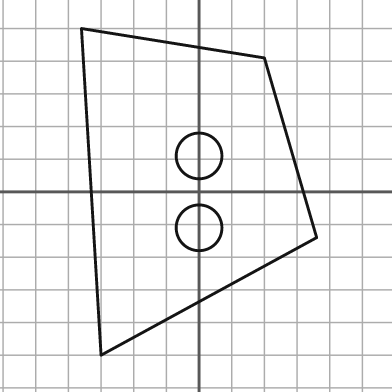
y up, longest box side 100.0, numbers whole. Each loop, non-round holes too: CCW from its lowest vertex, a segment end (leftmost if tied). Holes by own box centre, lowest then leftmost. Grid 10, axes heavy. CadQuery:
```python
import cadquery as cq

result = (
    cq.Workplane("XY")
    .moveTo(-30.0, -50.0)
    .lineTo(36.0, -14.0)
    .lineTo(20.0, 41.0)
    .lineTo(-36.0, 50.0)
    .close()
    .moveTo(0.0, -11.0)
    .circle(7.0)
    .moveTo(0.0, 11.0)
    .circle(7.0)
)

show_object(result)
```